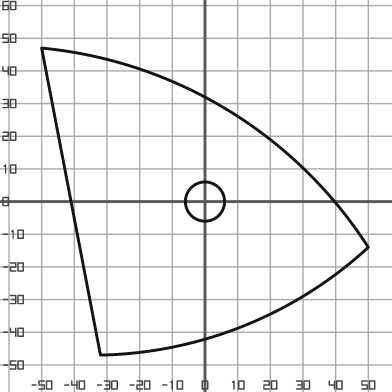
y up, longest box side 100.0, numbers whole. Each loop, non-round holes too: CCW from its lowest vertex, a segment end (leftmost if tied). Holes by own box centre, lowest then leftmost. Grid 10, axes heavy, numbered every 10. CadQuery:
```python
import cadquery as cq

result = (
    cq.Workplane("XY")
    .moveTo(-32.0, -47.0)
    .threePointArc((12.0, -38.0), (50.0, -14.0))
    .threePointArc((7.0, 28.0), (-50.0, 47.0))
    .close()
    .moveTo(0.0, 0.0)
    .circle(6.0)
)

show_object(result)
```